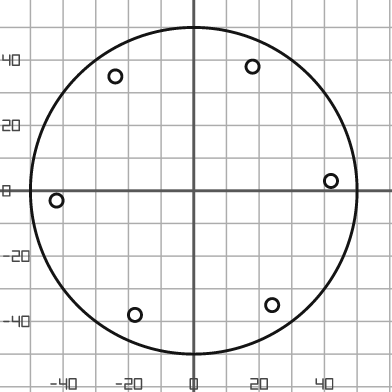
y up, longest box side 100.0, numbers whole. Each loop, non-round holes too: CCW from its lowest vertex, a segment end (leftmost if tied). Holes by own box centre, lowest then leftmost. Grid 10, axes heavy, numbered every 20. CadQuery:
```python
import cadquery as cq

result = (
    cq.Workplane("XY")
    .moveTo(0.0, 0.0)
    .circle(50.0)
    .moveTo(-18.0, -38.0)
    .circle(2.0)
    .moveTo(24.0, -35.0)
    .circle(2.0)
    .moveTo(-42.0, -3.0)
    .circle(2.0)
    .moveTo(42.0, 3.0)
    .circle(2.0)
    .moveTo(-24.0, 35.0)
    .circle(2.0)
    .moveTo(18.0, 38.0)
    .circle(2.0)
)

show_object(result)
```